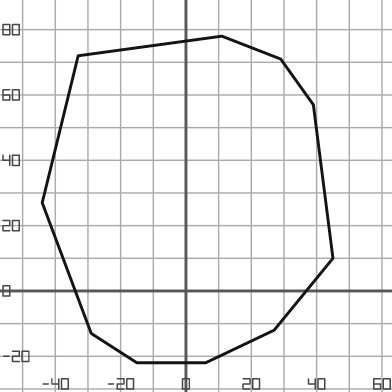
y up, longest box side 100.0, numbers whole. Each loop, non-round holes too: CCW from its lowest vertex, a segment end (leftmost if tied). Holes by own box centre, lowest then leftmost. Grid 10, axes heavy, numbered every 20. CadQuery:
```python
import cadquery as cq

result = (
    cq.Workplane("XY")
    .moveTo(-15.0, -22.0)
    .lineTo(6.0, -22.0)
    .lineTo(27.0, -12.0)
    .lineTo(45.0, 10.0)
    .lineTo(39.0, 57.0)
    .lineTo(29.0, 71.0)
    .lineTo(11.0, 78.0)
    .lineTo(-33.0, 72.0)
    .lineTo(-44.0, 27.0)
    .lineTo(-29.0, -13.0)
    .close()
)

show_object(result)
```